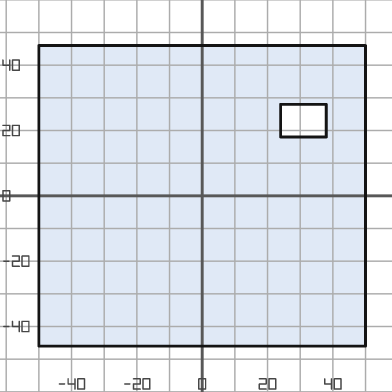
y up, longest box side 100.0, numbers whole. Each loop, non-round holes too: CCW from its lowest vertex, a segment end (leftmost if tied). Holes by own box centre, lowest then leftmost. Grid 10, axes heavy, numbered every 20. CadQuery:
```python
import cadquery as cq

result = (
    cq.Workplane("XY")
    .moveTo(-50.0, -46.0)
    .lineTo(50.0, -46.0)
    .lineTo(50.0, 46.0)
    .lineTo(-50.0, 46.0)
    .close()
    .moveTo(24.0, 18.0)
    .lineTo(38.0, 18.0)
    .lineTo(38.0, 28.0)
    .lineTo(24.0, 28.0)
    .close()
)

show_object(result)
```